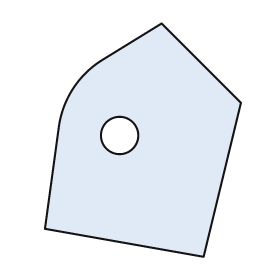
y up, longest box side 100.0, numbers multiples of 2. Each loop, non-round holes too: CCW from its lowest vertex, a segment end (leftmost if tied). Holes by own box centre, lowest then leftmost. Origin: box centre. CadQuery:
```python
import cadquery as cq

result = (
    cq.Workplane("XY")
    .moveTo(26.0, -50.0)
    .lineTo(42.0, 16.0)
    .lineTo(8.0, 50.0)
    .lineTo(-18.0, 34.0)
    .threePointArc((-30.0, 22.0), (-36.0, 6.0))
    .lineTo(-42.0, -38.0)
    .close()
    .moveTo(-10.0, 2.0)
    .circle(8.0)
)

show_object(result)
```